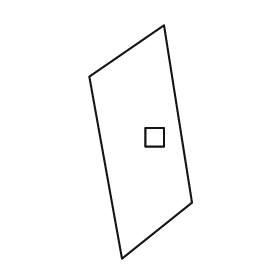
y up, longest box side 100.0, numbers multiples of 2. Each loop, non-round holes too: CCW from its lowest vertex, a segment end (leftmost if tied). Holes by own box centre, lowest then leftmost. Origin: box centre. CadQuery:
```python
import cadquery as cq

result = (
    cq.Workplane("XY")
    .moveTo(-8.0, -50.0)
    .lineTo(22.0, -26.0)
    .lineTo(10.0, 50.0)
    .lineTo(-22.0, 28.0)
    .close()
    .moveTo(2.0, -2.0)
    .lineTo(10.0, -2.0)
    .lineTo(10.0, 6.0)
    .lineTo(2.0, 6.0)
    .close()
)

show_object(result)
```